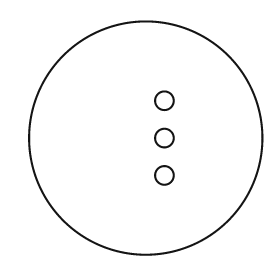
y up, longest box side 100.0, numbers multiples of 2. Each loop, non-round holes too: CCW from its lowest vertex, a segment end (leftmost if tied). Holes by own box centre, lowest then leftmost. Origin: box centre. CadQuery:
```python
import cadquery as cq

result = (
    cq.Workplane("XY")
    .moveTo(0.0, 0.0)
    .circle(50.0)
    .moveTo(8.0, -16.0)
    .circle(4.0)
    .moveTo(8.0, 0.0)
    .circle(4.0)
    .moveTo(8.0, 16.0)
    .circle(4.0)
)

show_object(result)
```